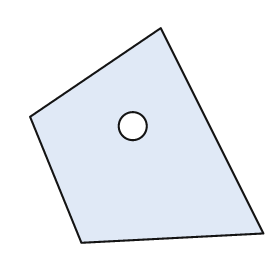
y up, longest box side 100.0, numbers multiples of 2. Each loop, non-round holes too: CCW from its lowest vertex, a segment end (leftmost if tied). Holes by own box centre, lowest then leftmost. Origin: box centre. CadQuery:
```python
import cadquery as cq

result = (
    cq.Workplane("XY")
    .moveTo(-28.0, -46.0)
    .lineTo(50.0, -42.0)
    .lineTo(6.0, 46.0)
    .lineTo(-50.0, 8.0)
    .close()
    .moveTo(-6.0, 4.0)
    .circle(6.0)
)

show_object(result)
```